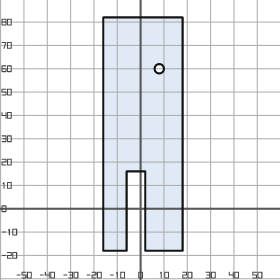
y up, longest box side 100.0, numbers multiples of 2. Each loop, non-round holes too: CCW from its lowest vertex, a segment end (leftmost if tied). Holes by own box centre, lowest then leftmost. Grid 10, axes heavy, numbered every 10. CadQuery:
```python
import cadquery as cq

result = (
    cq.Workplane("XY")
    .moveTo(-16.0, -18.0)
    .lineTo(-6.0, -18.0)
    .lineTo(-6.0, 16.0)
    .lineTo(2.0, 16.0)
    .lineTo(2.0, -18.0)
    .lineTo(18.0, -18.0)
    .lineTo(18.0, 82.0)
    .lineTo(-16.0, 82.0)
    .close()
    .moveTo(8.0, 60.0)
    .circle(2.0)
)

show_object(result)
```